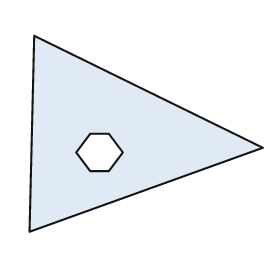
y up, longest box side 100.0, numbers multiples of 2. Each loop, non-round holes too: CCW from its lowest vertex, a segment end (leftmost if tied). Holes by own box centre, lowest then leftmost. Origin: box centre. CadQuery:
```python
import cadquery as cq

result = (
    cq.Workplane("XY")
    .moveTo(-50.0, -42.0)
    .lineTo(50.0, -6.0)
    .lineTo(-48.0, 42.0)
    .close()
    .moveTo(-24.0, -16.0)
    .lineTo(-16.0, -16.0)
    .lineTo(-10.0, -8.0)
    .lineTo(-16.0, 0.0)
    .lineTo(-24.0, 0.0)
    .lineTo(-30.0, -8.0)
    .close()
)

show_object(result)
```